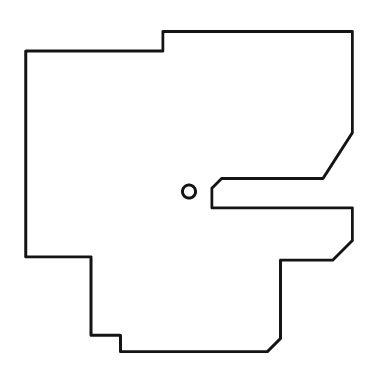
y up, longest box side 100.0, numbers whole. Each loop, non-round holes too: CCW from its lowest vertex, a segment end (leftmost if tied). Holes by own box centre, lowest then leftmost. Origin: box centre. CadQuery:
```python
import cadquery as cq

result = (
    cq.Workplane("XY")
    .moveTo(-21.0, -49.0)
    .lineTo(24.0, -49.0)
    .lineTo(28.0, -45.0)
    .lineTo(28.0, -21.0)
    .lineTo(44.0, -21.0)
    .lineTo(50.0, -15.0)
    .lineTo(50.0, -5.0)
    .lineTo(7.0, -5.0)
    .lineTo(7.0, 1.0)
    .lineTo(10.0, 4.0)
    .lineTo(41.0, 4.0)
    .lineTo(50.0, 18.0)
    .lineTo(50.0, 49.0)
    .lineTo(-8.0, 49.0)
    .lineTo(-8.0, 43.0)
    .lineTo(-50.0, 43.0)
    .lineTo(-50.0, -20.0)
    .lineTo(-30.0, -20.0)
    .lineTo(-30.0, -44.0)
    .lineTo(-21.0, -44.0)
    .close()
    .moveTo(0.0, 0.0)
    .circle(2.0)
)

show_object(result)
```